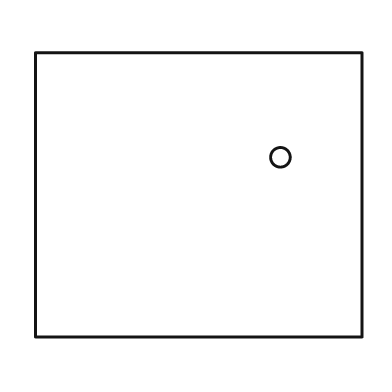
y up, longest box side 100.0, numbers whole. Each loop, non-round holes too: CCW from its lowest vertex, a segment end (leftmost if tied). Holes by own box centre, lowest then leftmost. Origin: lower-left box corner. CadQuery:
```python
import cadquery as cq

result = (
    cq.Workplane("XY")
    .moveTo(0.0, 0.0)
    .lineTo(100.0, 0.0)
    .lineTo(100.0, 87.0)
    .lineTo(0.0, 87.0)
    .close()
    .moveTo(75.0, 55.0)
    .circle(3.0)
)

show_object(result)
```